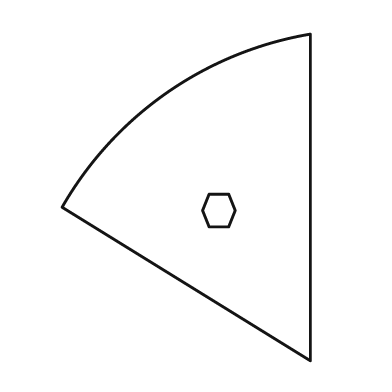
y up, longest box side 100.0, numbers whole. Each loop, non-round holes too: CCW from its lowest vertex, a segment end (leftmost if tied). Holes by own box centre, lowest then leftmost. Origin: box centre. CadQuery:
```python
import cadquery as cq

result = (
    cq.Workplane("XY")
    .moveTo(38.0, -50.0)
    .lineTo(38.0, 50.0)
    .threePointArc((-6.0, 32.0), (-38.0, -3.0))
    .close()
    .moveTo(7.0, -9.0)
    .lineTo(13.0, -9.0)
    .lineTo(15.0, -4.0)
    .lineTo(13.0, 1.0)
    .lineTo(7.0, 1.0)
    .lineTo(5.0, -4.0)
    .close()
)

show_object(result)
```